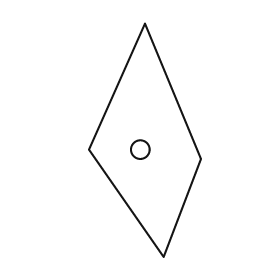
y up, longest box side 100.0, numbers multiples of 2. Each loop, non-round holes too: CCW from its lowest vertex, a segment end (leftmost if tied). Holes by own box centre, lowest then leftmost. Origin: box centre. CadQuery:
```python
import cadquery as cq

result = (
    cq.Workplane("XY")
    .moveTo(8.0, -50.0)
    .lineTo(24.0, -8.0)
    .lineTo(0.0, 50.0)
    .lineTo(-24.0, -4.0)
    .close()
    .moveTo(-2.0, -4.0)
    .circle(4.0)
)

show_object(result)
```